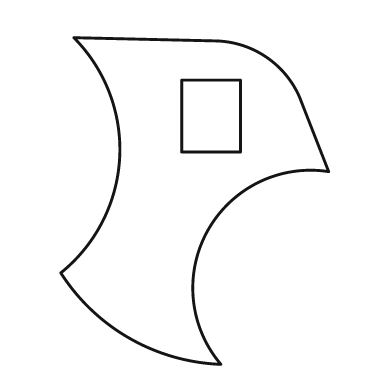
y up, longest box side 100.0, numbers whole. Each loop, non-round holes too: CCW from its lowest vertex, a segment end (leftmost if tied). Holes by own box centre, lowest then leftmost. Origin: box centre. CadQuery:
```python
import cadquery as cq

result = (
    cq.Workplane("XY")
    .moveTo(8.0, -50.0)
    .threePointArc((4.0, -9.0), (41.0, 9.0))
    .lineTo(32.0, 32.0)
    .threePointArc((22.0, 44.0), (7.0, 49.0))
    .lineTo(-37.0, 50.0)
    .threePointArc((-23.0, 13.0), (-41.0, -22.0))
    .threePointArc((-20.0, -42.0), (8.0, -50.0))
    .close()
    .moveTo(-4.0, 15.0)
    .lineTo(14.0, 15.0)
    .lineTo(14.0, 37.0)
    .lineTo(-4.0, 37.0)
    .close()
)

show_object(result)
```